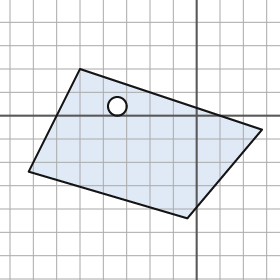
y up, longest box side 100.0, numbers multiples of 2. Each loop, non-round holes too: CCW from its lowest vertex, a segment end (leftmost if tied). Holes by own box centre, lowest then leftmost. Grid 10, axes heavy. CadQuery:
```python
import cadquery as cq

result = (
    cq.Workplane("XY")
    .moveTo(-4.0, -44.0)
    .lineTo(28.0, -6.0)
    .lineTo(-50.0, 20.0)
    .lineTo(-72.0, -24.0)
    .close()
    .moveTo(-34.0, 4.0)
    .circle(4.0)
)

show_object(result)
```